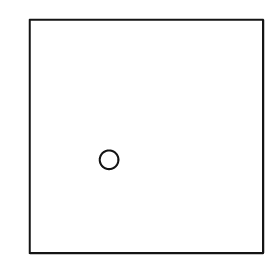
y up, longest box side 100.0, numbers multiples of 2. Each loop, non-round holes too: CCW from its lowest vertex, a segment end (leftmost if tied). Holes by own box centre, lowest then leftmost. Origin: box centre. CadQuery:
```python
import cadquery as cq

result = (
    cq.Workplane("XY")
    .moveTo(-50.0, -50.0)
    .lineTo(50.0, -50.0)
    .lineTo(50.0, 50.0)
    .lineTo(-50.0, 50.0)
    .close()
    .moveTo(-16.0, -10.0)
    .circle(4.0)
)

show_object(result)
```